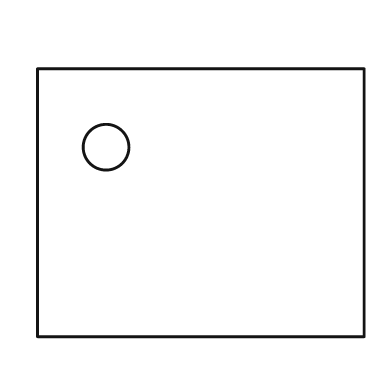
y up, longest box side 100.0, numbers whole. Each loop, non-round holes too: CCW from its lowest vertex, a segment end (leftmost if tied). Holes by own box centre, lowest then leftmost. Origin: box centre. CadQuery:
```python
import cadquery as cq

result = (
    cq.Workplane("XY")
    .moveTo(-50.0, -41.0)
    .lineTo(50.0, -41.0)
    .lineTo(50.0, 41.0)
    .lineTo(-50.0, 41.0)
    .close()
    .moveTo(-29.0, 17.0)
    .circle(7.0)
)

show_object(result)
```